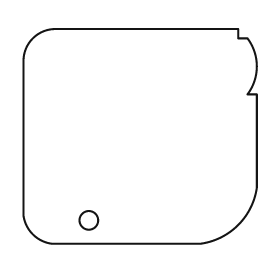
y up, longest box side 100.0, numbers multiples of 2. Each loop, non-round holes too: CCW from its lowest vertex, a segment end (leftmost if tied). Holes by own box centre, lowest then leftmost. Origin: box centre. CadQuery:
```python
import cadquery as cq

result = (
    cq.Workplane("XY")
    .moveTo(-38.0, -46.0)
    .lineTo(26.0, -46.0)
    .threePointArc((42.0, -38.0), (50.0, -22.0))
    .lineTo(50.0, 18.0)
    .lineTo(46.0, 18.0)
    .threePointArc((50.0, 30.0), (46.0, 42.0))
    .lineTo(42.0, 42.0)
    .lineTo(42.0, 46.0)
    .lineTo(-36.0, 46.0)
    .threePointArc((-46.0, 42.0), (-50.0, 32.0))
    .lineTo(-50.0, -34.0)
    .threePointArc((-46.0, -42.0), (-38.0, -46.0))
    .close()
    .moveTo(-22.0, -36.0)
    .circle(4.0)
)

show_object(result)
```